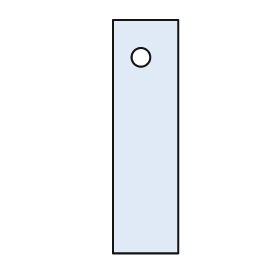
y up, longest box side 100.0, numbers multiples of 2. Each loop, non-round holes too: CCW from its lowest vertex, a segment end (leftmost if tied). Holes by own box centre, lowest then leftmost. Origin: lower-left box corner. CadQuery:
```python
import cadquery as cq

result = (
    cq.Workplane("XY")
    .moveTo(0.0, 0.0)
    .lineTo(28.0, 0.0)
    .lineTo(28.0, 100.0)
    .lineTo(0.0, 100.0)
    .close()
    .moveTo(12.0, 84.0)
    .circle(4.0)
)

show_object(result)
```